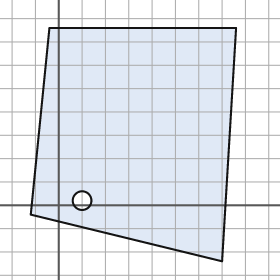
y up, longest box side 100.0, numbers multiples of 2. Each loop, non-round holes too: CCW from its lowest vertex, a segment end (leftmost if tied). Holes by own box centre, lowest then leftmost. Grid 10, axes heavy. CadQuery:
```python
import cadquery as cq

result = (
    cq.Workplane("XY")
    .moveTo(70.0, -24.0)
    .lineTo(76.0, 76.0)
    .lineTo(-4.0, 76.0)
    .lineTo(-12.0, -4.0)
    .close()
    .moveTo(10.0, 2.0)
    .circle(4.0)
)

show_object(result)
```